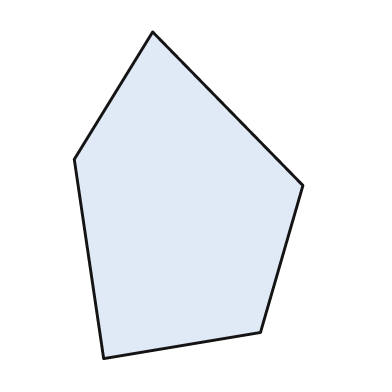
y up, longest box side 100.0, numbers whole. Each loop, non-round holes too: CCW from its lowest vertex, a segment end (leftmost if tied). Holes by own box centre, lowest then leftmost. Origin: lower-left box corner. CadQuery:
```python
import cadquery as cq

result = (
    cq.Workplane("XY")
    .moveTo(9.0, 0.0)
    .lineTo(57.0, 8.0)
    .lineTo(70.0, 53.0)
    .lineTo(24.0, 100.0)
    .lineTo(0.0, 61.0)
    .close()
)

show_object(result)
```